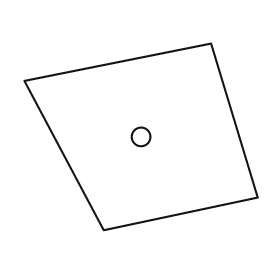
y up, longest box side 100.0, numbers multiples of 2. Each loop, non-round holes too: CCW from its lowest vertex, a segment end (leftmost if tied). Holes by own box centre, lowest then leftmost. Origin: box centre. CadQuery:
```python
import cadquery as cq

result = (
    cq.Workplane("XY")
    .moveTo(-16.0, -40.0)
    .lineTo(50.0, -26.0)
    .lineTo(30.0, 40.0)
    .lineTo(-50.0, 24.0)
    .close()
    .moveTo(0.0, 0.0)
    .circle(4.0)
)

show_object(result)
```